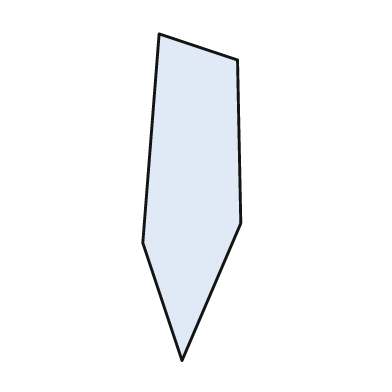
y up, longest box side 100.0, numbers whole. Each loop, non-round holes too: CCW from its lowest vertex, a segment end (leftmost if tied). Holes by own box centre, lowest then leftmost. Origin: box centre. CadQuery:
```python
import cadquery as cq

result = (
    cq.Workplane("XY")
    .moveTo(-3.0, -50.0)
    .lineTo(15.0, -8.0)
    .lineTo(14.0, 42.0)
    .lineTo(-10.0, 50.0)
    .lineTo(-15.0, -14.0)
    .close()
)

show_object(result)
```